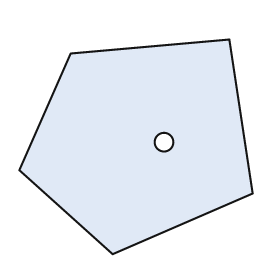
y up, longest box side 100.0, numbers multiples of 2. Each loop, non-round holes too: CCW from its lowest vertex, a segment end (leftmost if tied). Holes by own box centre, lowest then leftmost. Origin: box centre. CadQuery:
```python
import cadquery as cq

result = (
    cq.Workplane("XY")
    .moveTo(-10.0, -46.0)
    .lineTo(50.0, -20.0)
    .lineTo(40.0, 46.0)
    .lineTo(-28.0, 40.0)
    .lineTo(-50.0, -10.0)
    .close()
    .moveTo(12.0, 2.0)
    .circle(4.0)
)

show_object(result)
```